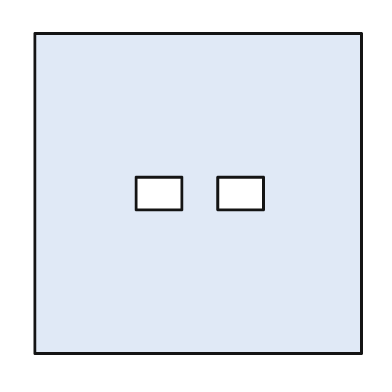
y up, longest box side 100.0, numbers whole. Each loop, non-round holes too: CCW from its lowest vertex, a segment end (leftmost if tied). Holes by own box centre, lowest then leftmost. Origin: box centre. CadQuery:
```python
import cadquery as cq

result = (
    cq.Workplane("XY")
    .moveTo(-50.0, -49.0)
    .lineTo(50.0, -49.0)
    .lineTo(50.0, 49.0)
    .lineTo(-50.0, 49.0)
    .close()
    .moveTo(-19.0, -5.0)
    .lineTo(-5.0, -5.0)
    .lineTo(-5.0, 5.0)
    .lineTo(-19.0, 5.0)
    .close()
    .moveTo(6.0, -5.0)
    .lineTo(20.0, -5.0)
    .lineTo(20.0, 5.0)
    .lineTo(6.0, 5.0)
    .close()
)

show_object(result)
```